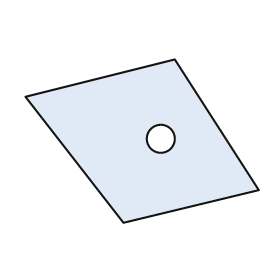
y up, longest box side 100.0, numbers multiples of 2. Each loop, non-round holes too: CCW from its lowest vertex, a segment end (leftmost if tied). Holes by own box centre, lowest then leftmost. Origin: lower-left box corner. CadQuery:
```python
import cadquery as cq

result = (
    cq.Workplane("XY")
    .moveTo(42.0, 0.0)
    .lineTo(100.0, 14.0)
    .lineTo(64.0, 70.0)
    .lineTo(0.0, 54.0)
    .close()
    .moveTo(58.0, 36.0)
    .circle(6.0)
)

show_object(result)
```